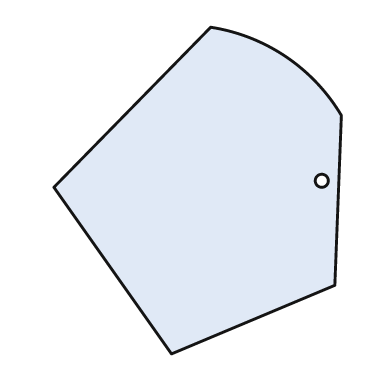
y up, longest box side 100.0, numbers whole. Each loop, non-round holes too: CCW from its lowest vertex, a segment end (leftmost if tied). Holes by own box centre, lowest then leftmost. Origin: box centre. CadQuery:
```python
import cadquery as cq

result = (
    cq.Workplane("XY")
    .moveTo(-8.0, -50.0)
    .lineTo(42.0, -29.0)
    .lineTo(44.0, 23.0)
    .threePointArc((27.0, 41.0), (4.0, 50.0))
    .lineTo(-44.0, 1.0)
    .close()
    .moveTo(38.0, 3.0)
    .circle(2.0)
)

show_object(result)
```